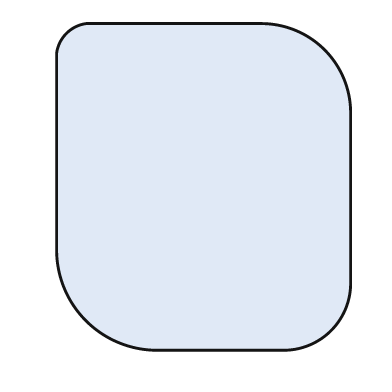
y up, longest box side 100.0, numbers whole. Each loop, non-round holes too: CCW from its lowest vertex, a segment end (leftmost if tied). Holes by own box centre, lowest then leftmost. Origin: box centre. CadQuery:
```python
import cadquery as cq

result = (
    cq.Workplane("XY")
    .moveTo(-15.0, -50.0)
    .lineTo(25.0, -50.0)
    .threePointArc((39.0, -44.0), (45.0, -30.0))
    .lineTo(45.0, 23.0)
    .threePointArc((37.0, 42.0), (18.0, 50.0))
    .lineTo(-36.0, 50.0)
    .threePointArc((-42.0, 47.0), (-45.0, 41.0))
    .lineTo(-45.0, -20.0)
    .threePointArc((-36.0, -41.0), (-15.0, -50.0))
    .close()
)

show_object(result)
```